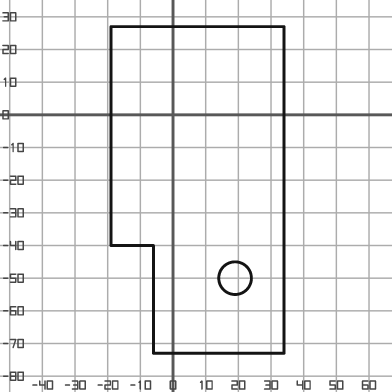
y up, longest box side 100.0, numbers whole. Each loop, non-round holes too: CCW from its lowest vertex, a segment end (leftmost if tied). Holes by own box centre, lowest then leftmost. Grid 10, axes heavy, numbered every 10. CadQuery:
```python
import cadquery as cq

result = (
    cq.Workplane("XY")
    .moveTo(-6.0, -73.0)
    .lineTo(34.0, -73.0)
    .lineTo(34.0, 27.0)
    .lineTo(-19.0, 27.0)
    .lineTo(-19.0, -40.0)
    .lineTo(-6.0, -40.0)
    .close()
    .moveTo(19.0, -50.0)
    .circle(5.0)
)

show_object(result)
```